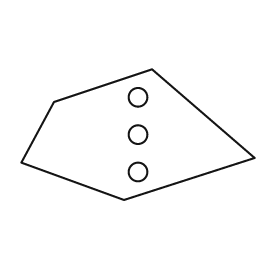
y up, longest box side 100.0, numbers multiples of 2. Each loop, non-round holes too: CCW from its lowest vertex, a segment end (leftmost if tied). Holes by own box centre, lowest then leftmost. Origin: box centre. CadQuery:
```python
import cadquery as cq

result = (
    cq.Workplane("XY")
    .moveTo(-6.0, -28.0)
    .lineTo(50.0, -10.0)
    .lineTo(6.0, 28.0)
    .lineTo(-36.0, 14.0)
    .lineTo(-50.0, -12.0)
    .close()
    .moveTo(0.0, -16.0)
    .circle(4.0)
    .moveTo(0.0, 0.0)
    .circle(4.0)
    .moveTo(0.0, 16.0)
    .circle(4.0)
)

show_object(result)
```